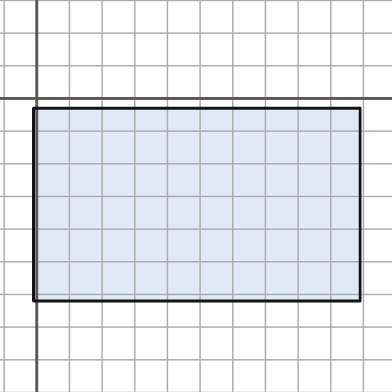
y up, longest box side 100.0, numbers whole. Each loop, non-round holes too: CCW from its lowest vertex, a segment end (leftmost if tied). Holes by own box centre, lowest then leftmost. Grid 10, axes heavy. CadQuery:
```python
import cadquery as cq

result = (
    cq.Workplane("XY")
    .moveTo(-1.0, -62.0)
    .lineTo(99.0, -62.0)
    .lineTo(99.0, -3.0)
    .lineTo(-1.0, -3.0)
    .close()
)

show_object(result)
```